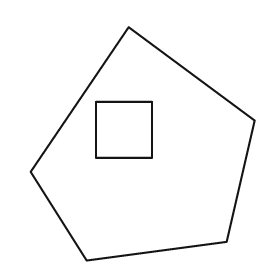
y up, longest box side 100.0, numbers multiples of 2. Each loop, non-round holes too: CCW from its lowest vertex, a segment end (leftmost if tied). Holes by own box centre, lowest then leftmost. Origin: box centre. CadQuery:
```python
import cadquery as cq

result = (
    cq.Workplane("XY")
    .moveTo(-24.0, -50.0)
    .lineTo(36.0, -42.0)
    .lineTo(48.0, 10.0)
    .lineTo(-6.0, 50.0)
    .lineTo(-48.0, -12.0)
    .close()
    .moveTo(-20.0, -6.0)
    .lineTo(4.0, -6.0)
    .lineTo(4.0, 18.0)
    .lineTo(-20.0, 18.0)
    .close()
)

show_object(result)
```